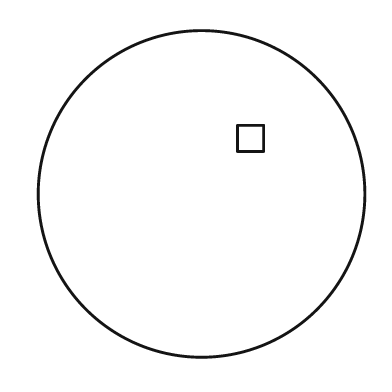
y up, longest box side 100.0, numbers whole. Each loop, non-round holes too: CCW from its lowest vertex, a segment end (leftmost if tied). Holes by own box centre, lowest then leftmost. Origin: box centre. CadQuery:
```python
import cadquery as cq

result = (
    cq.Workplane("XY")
    .moveTo(0.0, 0.0)
    .circle(50.0)
    .moveTo(11.0, 13.0)
    .lineTo(19.0, 13.0)
    .lineTo(19.0, 21.0)
    .lineTo(11.0, 21.0)
    .close()
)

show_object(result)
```